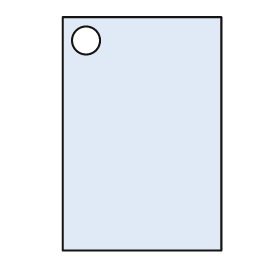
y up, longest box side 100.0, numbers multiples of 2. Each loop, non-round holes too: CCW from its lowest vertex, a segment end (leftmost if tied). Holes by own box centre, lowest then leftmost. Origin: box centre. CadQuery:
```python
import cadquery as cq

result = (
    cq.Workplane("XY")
    .moveTo(-34.0, -50.0)
    .lineTo(34.0, -50.0)
    .lineTo(34.0, 50.0)
    .lineTo(-34.0, 50.0)
    .close()
    .moveTo(-24.0, 40.0)
    .circle(6.0)
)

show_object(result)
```